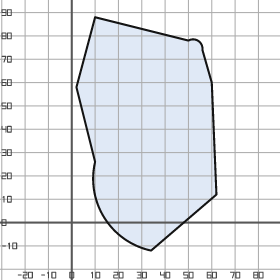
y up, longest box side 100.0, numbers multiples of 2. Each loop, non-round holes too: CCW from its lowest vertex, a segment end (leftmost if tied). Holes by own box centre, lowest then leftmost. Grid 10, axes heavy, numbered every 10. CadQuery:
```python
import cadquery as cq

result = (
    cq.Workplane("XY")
    .moveTo(34.0, -12.0)
    .lineTo(62.0, 12.0)
    .lineTo(60.0, 60.0)
    .lineTo(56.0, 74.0)
    .threePointArc((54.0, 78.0), (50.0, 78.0))
    .lineTo(10.0, 88.0)
    .lineTo(2.0, 58.0)
    .lineTo(10.0, 26.0)
    .threePointArc((14.0, 2.0), (34.0, -12.0))
    .close()
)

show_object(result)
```